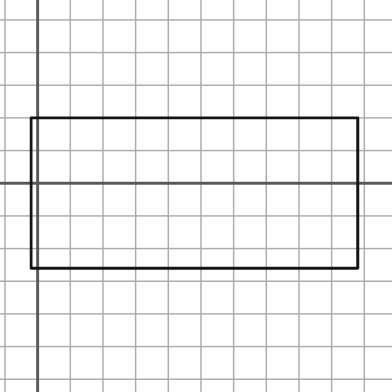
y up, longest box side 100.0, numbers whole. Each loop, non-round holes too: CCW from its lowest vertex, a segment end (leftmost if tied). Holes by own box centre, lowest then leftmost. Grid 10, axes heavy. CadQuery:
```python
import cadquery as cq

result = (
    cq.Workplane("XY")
    .moveTo(-2.0, -26.0)
    .lineTo(98.0, -26.0)
    .lineTo(98.0, 20.0)
    .lineTo(-2.0, 20.0)
    .close()
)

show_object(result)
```